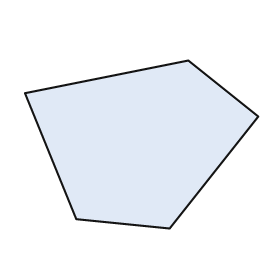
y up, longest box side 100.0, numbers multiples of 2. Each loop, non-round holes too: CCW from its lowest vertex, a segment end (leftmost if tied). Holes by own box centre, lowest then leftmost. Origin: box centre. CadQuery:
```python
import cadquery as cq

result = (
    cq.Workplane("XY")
    .moveTo(12.0, -36.0)
    .lineTo(50.0, 12.0)
    .lineTo(20.0, 36.0)
    .lineTo(-50.0, 22.0)
    .lineTo(-28.0, -32.0)
    .close()
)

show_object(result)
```